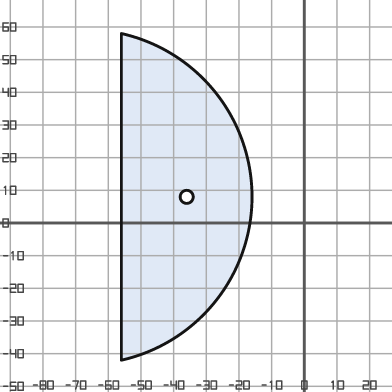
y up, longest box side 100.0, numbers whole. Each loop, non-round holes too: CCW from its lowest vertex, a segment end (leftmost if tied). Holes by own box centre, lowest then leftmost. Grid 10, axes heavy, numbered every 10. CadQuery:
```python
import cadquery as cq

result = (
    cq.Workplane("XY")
    .moveTo(-56.0, -42.0)
    .threePointArc((-16.0, 8.0), (-56.0, 58.0))
    .close()
    .moveTo(-36.0, 8.0)
    .circle(2.0)
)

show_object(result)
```